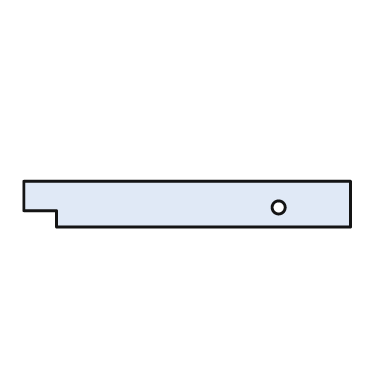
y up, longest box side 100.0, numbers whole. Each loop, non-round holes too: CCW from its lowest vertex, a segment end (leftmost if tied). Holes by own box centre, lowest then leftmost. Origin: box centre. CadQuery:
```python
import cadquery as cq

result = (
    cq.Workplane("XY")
    .moveTo(-40.0, -7.0)
    .lineTo(50.0, -7.0)
    .lineTo(50.0, 7.0)
    .lineTo(-50.0, 7.0)
    .lineTo(-50.0, -2.0)
    .lineTo(-40.0, -2.0)
    .close()
    .moveTo(28.0, -1.0)
    .circle(2.0)
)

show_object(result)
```